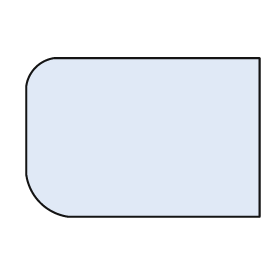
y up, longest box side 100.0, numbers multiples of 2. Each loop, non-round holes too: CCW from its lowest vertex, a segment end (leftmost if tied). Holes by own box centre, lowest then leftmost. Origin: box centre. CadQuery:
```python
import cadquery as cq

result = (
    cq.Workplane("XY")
    .moveTo(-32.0, -34.0)
    .lineTo(50.0, -34.0)
    .lineTo(50.0, 34.0)
    .lineTo(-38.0, 34.0)
    .threePointArc((-46.0, 30.0), (-50.0, 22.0))
    .lineTo(-50.0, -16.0)
    .threePointArc((-44.0, -28.0), (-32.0, -34.0))
    .close()
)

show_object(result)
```